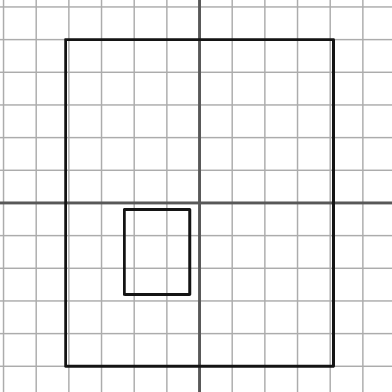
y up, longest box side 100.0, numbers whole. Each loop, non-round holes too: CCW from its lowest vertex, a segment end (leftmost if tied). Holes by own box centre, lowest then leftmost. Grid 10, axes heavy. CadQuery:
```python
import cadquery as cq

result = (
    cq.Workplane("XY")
    .moveTo(-41.0, -50.0)
    .lineTo(41.0, -50.0)
    .lineTo(41.0, 50.0)
    .lineTo(-41.0, 50.0)
    .close()
    .moveTo(-23.0, -28.0)
    .lineTo(-3.0, -28.0)
    .lineTo(-3.0, -2.0)
    .lineTo(-23.0, -2.0)
    .close()
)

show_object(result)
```